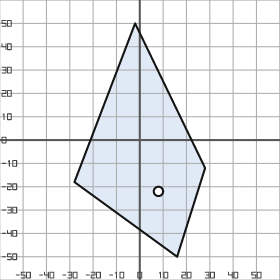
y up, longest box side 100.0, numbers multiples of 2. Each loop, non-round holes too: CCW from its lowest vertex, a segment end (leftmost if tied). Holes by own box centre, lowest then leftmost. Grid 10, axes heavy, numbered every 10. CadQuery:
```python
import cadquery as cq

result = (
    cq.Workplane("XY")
    .moveTo(16.0, -50.0)
    .lineTo(28.0, -12.0)
    .lineTo(-2.0, 50.0)
    .lineTo(-28.0, -18.0)
    .close()
    .moveTo(8.0, -22.0)
    .circle(2.0)
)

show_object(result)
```